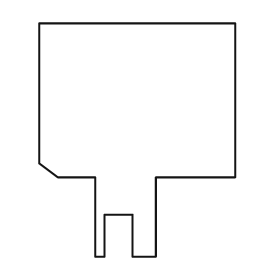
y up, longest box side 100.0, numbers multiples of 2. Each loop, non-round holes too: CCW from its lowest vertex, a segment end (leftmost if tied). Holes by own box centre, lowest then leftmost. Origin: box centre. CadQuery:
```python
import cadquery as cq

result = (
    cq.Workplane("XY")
    .moveTo(-18.0, -50.0)
    .lineTo(-14.0, -50.0)
    .lineTo(-14.0, -32.0)
    .lineTo(-2.0, -32.0)
    .lineTo(-2.0, -50.0)
    .lineTo(8.0, -50.0)
    .lineTo(8.0, -16.0)
    .lineTo(42.0, -16.0)
    .lineTo(42.0, 50.0)
    .lineTo(-42.0, 50.0)
    .lineTo(-42.0, -10.0)
    .lineTo(-34.0, -16.0)
    .lineTo(-18.0, -16.0)
    .close()
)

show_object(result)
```